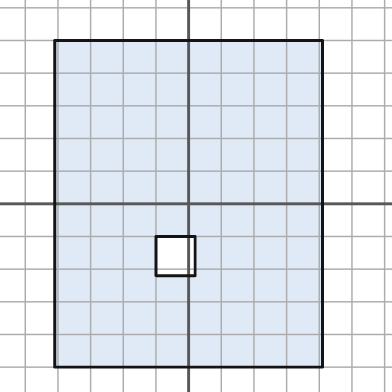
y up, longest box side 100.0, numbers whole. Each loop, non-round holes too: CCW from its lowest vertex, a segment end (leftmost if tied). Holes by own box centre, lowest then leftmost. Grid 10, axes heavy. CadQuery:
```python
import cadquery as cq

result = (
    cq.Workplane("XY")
    .moveTo(-41.0, -50.0)
    .lineTo(41.0, -50.0)
    .lineTo(41.0, 50.0)
    .lineTo(-41.0, 50.0)
    .close()
    .moveTo(-10.0, -22.0)
    .lineTo(2.0, -22.0)
    .lineTo(2.0, -10.0)
    .lineTo(-10.0, -10.0)
    .close()
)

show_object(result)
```